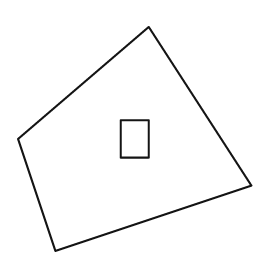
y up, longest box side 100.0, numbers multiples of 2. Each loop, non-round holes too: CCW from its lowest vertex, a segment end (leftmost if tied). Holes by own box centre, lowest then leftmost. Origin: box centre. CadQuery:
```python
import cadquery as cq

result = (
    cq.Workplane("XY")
    .moveTo(-34.0, -48.0)
    .lineTo(50.0, -20.0)
    .lineTo(6.0, 48.0)
    .lineTo(-50.0, 0.0)
    .close()
    .moveTo(-6.0, -8.0)
    .lineTo(6.0, -8.0)
    .lineTo(6.0, 8.0)
    .lineTo(-6.0, 8.0)
    .close()
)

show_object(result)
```